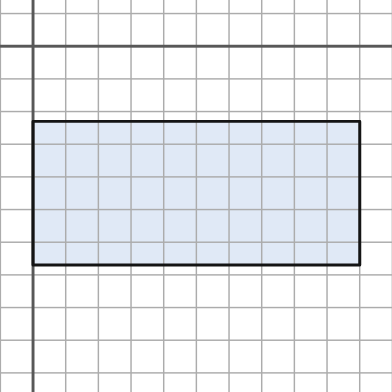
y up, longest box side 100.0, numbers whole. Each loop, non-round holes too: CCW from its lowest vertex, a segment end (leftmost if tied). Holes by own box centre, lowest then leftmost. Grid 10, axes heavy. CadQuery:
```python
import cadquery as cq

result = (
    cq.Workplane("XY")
    .moveTo(0.0, -67.0)
    .lineTo(100.0, -67.0)
    .lineTo(100.0, -23.0)
    .lineTo(0.0, -23.0)
    .close()
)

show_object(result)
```